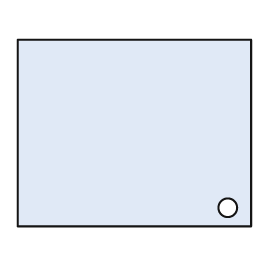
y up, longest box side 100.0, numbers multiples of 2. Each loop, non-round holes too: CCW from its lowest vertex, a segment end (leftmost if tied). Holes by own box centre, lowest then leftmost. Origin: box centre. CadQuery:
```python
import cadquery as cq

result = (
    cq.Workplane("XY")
    .moveTo(-50.0, -40.0)
    .lineTo(50.0, -40.0)
    .lineTo(50.0, 40.0)
    .lineTo(-50.0, 40.0)
    .close()
    .moveTo(40.0, -32.0)
    .circle(4.0)
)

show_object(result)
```